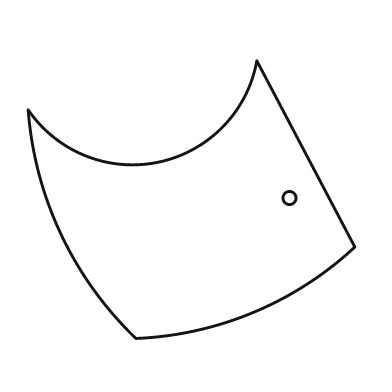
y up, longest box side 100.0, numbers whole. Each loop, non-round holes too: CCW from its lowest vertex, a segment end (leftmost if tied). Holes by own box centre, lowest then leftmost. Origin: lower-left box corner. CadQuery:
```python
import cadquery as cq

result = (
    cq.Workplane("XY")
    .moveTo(33.0, 0.0)
    .threePointArc((69.0, 8.0), (100.0, 28.0))
    .lineTo(70.0, 85.0)
    .threePointArc((40.0, 54.0), (0.0, 70.0))
    .threePointArc((10.0, 32.0), (33.0, 0.0))
    .close()
    .moveTo(80.0, 43.0)
    .circle(2.0)
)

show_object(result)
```